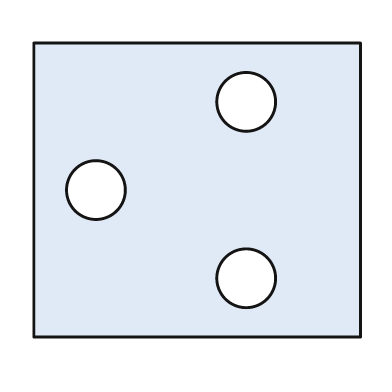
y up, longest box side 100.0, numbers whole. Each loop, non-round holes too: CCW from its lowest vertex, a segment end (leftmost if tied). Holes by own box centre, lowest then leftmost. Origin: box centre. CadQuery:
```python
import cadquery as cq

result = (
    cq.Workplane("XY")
    .moveTo(-50.0, -45.0)
    .lineTo(50.0, -45.0)
    .lineTo(50.0, 45.0)
    .lineTo(-50.0, 45.0)
    .close()
    .moveTo(15.0, -27.0)
    .circle(9.0)
    .moveTo(-31.0, 0.0)
    .circle(9.0)
    .moveTo(15.0, 27.0)
    .circle(9.0)
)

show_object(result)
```